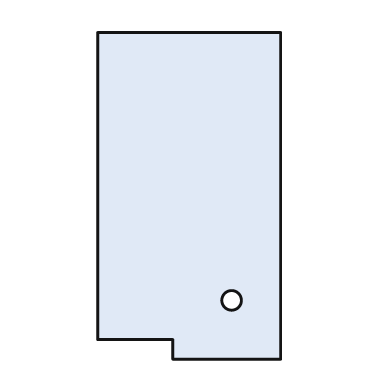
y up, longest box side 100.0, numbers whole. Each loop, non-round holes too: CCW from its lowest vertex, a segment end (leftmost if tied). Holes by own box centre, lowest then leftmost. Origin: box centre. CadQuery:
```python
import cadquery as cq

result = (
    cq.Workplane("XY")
    .moveTo(-5.0, -50.0)
    .lineTo(28.0, -50.0)
    .lineTo(28.0, 50.0)
    .lineTo(-28.0, 50.0)
    .lineTo(-28.0, -44.0)
    .lineTo(-5.0, -44.0)
    .close()
    .moveTo(13.0, -32.0)
    .circle(3.0)
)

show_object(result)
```